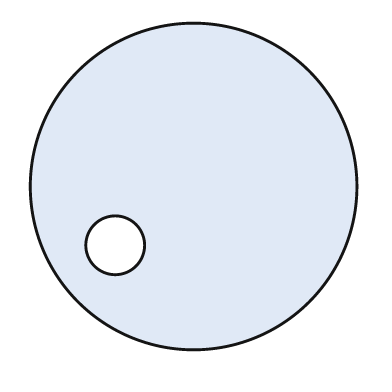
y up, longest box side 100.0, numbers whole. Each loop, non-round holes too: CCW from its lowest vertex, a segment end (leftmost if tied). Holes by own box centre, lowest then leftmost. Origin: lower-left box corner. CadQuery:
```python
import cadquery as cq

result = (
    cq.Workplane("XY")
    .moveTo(50.0, 50.0)
    .circle(50.0)
    .moveTo(26.0, 32.0)
    .circle(9.0)
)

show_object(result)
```